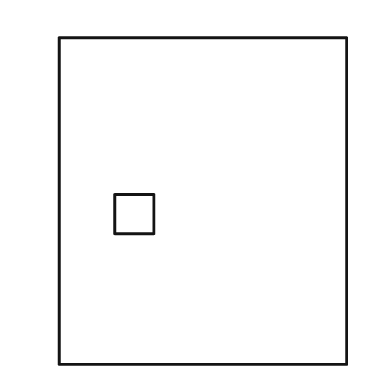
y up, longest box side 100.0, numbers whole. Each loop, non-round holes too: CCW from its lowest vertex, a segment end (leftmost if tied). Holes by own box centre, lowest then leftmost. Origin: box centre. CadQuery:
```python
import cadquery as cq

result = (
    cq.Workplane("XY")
    .moveTo(-44.0, -50.0)
    .lineTo(44.0, -50.0)
    .lineTo(44.0, 50.0)
    .lineTo(-44.0, 50.0)
    .close()
    .moveTo(-27.0, -10.0)
    .lineTo(-15.0, -10.0)
    .lineTo(-15.0, 2.0)
    .lineTo(-27.0, 2.0)
    .close()
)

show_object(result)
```